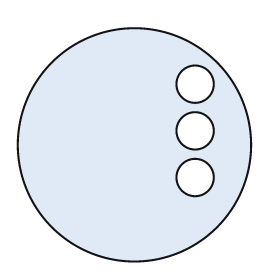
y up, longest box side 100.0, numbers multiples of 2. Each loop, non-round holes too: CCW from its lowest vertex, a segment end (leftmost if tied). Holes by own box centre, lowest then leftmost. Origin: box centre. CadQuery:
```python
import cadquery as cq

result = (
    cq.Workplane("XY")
    .moveTo(0.0, 0.0)
    .circle(50.0)
    .moveTo(26.0, -14.0)
    .circle(8.0)
    .moveTo(26.0, 6.0)
    .circle(8.0)
    .moveTo(26.0, 26.0)
    .circle(8.0)
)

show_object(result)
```